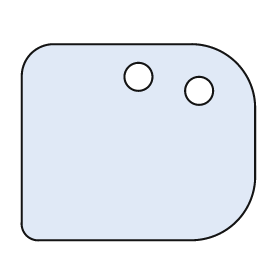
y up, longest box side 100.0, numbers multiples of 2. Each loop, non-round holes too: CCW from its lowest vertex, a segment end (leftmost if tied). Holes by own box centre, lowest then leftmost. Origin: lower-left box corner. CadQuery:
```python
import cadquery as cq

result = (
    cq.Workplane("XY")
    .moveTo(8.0, 0.0)
    .lineTo(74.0, 0.0)
    .threePointArc((92.0, 8.0), (100.0, 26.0))
    .lineTo(100.0, 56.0)
    .threePointArc((92.0, 76.0), (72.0, 84.0))
    .lineTo(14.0, 84.0)
    .threePointArc((4.0, 80.0), (0.0, 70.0))
    .lineTo(0.0, 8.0)
    .threePointArc((2.0, 2.0), (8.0, 0.0))
    .close()
    .moveTo(76.0, 64.0)
    .circle(6.0)
    .moveTo(50.0, 70.0)
    .circle(6.0)
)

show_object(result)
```